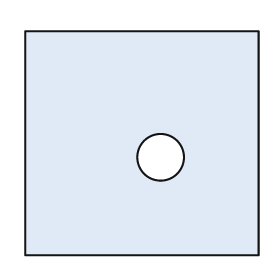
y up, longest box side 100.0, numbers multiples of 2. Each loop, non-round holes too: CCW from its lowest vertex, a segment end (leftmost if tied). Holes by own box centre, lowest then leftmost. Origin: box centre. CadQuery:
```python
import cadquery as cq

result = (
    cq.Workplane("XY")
    .moveTo(-50.0, -48.0)
    .lineTo(50.0, -48.0)
    .lineTo(50.0, 48.0)
    .lineTo(-50.0, 48.0)
    .close()
    .moveTo(8.0, -6.0)
    .circle(10.0)
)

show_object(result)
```